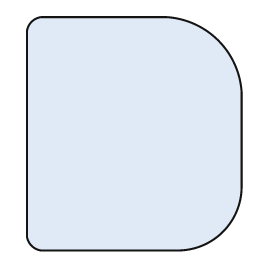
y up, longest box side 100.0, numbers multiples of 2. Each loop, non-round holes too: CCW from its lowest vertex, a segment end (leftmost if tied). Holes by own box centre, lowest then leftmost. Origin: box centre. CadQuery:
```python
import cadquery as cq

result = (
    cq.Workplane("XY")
    .moveTo(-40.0, -50.0)
    .lineTo(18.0, -50.0)
    .threePointArc((38.0, -42.0), (46.0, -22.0))
    .lineTo(46.0, 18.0)
    .threePointArc((36.0, 40.0), (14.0, 50.0))
    .lineTo(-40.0, 50.0)
    .threePointArc((-44.0, 48.0), (-46.0, 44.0))
    .lineTo(-46.0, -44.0)
    .threePointArc((-44.0, -48.0), (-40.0, -50.0))
    .close()
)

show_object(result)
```